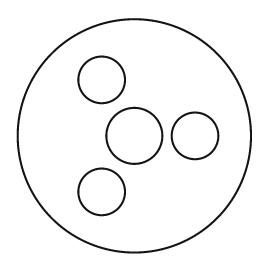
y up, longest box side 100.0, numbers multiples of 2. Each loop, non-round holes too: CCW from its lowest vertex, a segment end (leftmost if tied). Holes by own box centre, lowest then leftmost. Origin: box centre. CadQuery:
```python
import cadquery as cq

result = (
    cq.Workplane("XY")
    .moveTo(0.0, 0.0)
    .circle(50.0)
    .moveTo(-14.0, -24.0)
    .circle(10.0)
    .moveTo(0.0, 0.0)
    .circle(12.0)
    .moveTo(26.0, 0.0)
    .circle(10.0)
    .moveTo(-14.0, 24.0)
    .circle(10.0)
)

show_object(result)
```